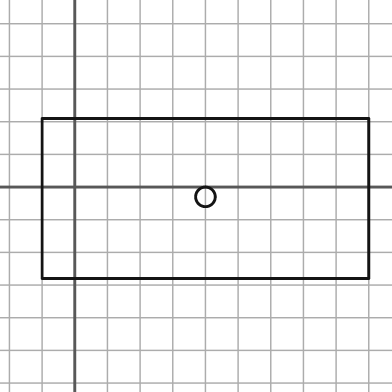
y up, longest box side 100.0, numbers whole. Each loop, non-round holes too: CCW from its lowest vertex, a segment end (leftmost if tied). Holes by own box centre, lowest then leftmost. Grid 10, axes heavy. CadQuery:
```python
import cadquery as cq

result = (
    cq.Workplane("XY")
    .moveTo(-10.0, -28.0)
    .lineTo(90.0, -28.0)
    .lineTo(90.0, 21.0)
    .lineTo(-10.0, 21.0)
    .close()
    .moveTo(40.0, -3.0)
    .circle(3.0)
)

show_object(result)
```